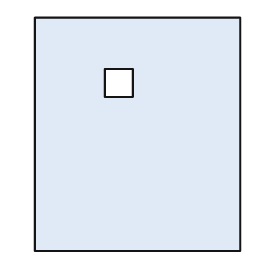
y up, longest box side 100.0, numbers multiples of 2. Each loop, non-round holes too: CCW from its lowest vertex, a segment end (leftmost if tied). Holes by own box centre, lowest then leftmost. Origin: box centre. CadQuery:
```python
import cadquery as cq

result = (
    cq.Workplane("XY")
    .moveTo(-44.0, -50.0)
    .lineTo(44.0, -50.0)
    .lineTo(44.0, 50.0)
    .lineTo(-44.0, 50.0)
    .close()
    .moveTo(-14.0, 16.0)
    .lineTo(-2.0, 16.0)
    .lineTo(-2.0, 28.0)
    .lineTo(-14.0, 28.0)
    .close()
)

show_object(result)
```